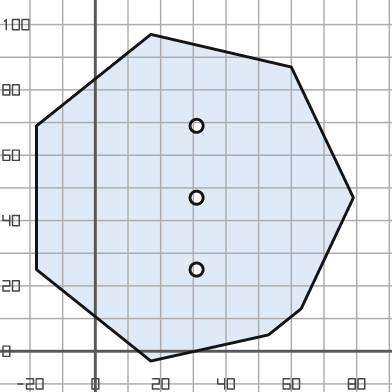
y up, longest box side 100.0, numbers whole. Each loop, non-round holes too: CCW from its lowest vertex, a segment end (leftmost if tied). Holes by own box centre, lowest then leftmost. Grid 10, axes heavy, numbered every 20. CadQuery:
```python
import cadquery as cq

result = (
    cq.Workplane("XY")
    .moveTo(17.0, -3.0)
    .lineTo(53.0, 5.0)
    .lineTo(63.0, 13.0)
    .lineTo(79.0, 47.0)
    .lineTo(60.0, 87.0)
    .lineTo(17.0, 97.0)
    .lineTo(-18.0, 69.0)
    .lineTo(-18.0, 25.0)
    .close()
    .moveTo(31.0, 25.0)
    .circle(2.0)
    .moveTo(31.0, 47.0)
    .circle(2.0)
    .moveTo(31.0, 69.0)
    .circle(2.0)
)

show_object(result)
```